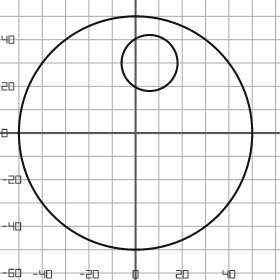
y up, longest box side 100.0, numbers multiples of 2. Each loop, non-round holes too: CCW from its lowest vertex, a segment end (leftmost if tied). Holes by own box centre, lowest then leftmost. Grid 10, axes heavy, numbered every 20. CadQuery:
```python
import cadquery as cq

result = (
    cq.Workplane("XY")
    .moveTo(0.0, 0.0)
    .circle(50.0)
    .moveTo(6.0, 30.0)
    .circle(12.0)
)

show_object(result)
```